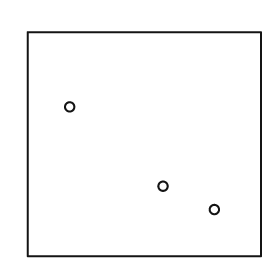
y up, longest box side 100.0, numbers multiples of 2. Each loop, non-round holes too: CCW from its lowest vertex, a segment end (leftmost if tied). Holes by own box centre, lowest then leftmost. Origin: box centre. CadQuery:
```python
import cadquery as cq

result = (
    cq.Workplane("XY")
    .moveTo(-50.0, -48.0)
    .lineTo(50.0, -48.0)
    .lineTo(50.0, 48.0)
    .lineTo(-50.0, 48.0)
    .close()
    .moveTo(30.0, -28.0)
    .circle(2.0)
    .moveTo(8.0, -18.0)
    .circle(2.0)
    .moveTo(-32.0, 16.0)
    .circle(2.0)
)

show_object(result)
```